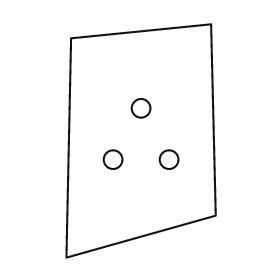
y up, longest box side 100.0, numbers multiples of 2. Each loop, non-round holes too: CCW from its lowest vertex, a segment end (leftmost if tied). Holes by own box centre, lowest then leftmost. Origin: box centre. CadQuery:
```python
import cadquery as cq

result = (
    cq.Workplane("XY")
    .moveTo(-32.0, -50.0)
    .lineTo(32.0, -32.0)
    .lineTo(30.0, 50.0)
    .lineTo(-30.0, 44.0)
    .close()
    .moveTo(-12.0, -8.0)
    .circle(4.0)
    .moveTo(12.0, -8.0)
    .circle(4.0)
    .moveTo(0.0, 14.0)
    .circle(4.0)
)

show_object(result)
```